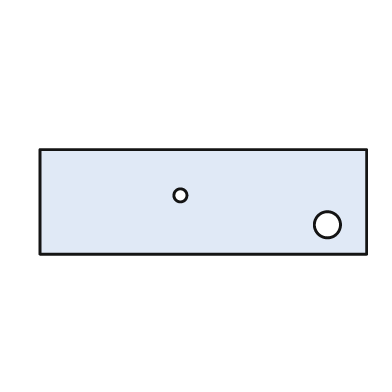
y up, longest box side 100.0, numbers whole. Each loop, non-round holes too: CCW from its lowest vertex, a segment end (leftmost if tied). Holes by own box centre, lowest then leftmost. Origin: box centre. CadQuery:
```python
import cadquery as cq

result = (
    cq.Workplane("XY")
    .moveTo(-50.0, -16.0)
    .lineTo(50.0, -16.0)
    .lineTo(50.0, 16.0)
    .lineTo(-50.0, 16.0)
    .close()
    .moveTo(38.0, -7.0)
    .circle(4.0)
    .moveTo(-7.0, 2.0)
    .circle(2.0)
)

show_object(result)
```